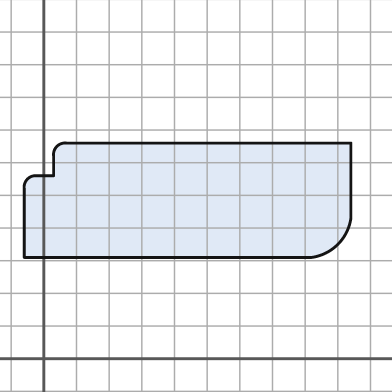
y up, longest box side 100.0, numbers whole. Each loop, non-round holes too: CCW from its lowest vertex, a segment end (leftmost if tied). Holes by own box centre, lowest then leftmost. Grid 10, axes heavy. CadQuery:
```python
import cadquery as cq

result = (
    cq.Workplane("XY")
    .moveTo(-6.0, 31.0)
    .lineTo(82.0, 31.0)
    .threePointArc((90.0, 35.0), (94.0, 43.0))
    .lineTo(94.0, 66.0)
    .lineTo(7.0, 66.0)
    .threePointArc((4.0, 65.0), (3.0, 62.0))
    .lineTo(3.0, 56.0)
    .lineTo(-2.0, 56.0)
    .threePointArc((-5.0, 55.0), (-6.0, 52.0))
    .close()
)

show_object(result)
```